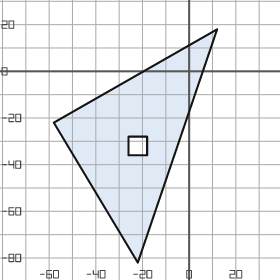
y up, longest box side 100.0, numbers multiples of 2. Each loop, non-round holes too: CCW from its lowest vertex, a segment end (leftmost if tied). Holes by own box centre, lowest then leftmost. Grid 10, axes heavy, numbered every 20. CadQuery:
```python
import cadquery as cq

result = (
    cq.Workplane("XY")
    .moveTo(-22.0, -82.0)
    .lineTo(12.0, 18.0)
    .lineTo(-58.0, -22.0)
    .close()
    .moveTo(-26.0, -36.0)
    .lineTo(-18.0, -36.0)
    .lineTo(-18.0, -28.0)
    .lineTo(-26.0, -28.0)
    .close()
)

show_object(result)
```